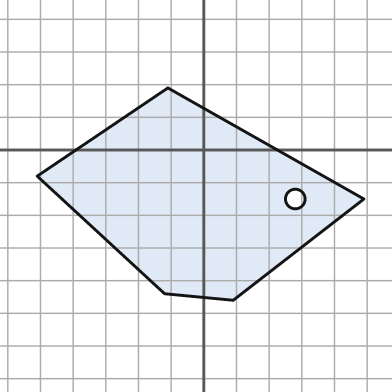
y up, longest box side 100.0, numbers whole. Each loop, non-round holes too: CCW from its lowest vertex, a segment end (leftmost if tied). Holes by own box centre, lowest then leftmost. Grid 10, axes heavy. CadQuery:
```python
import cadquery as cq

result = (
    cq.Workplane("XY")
    .moveTo(9.0, -46.0)
    .lineTo(49.0, -15.0)
    .lineTo(-11.0, 19.0)
    .lineTo(-51.0, -8.0)
    .lineTo(-12.0, -44.0)
    .close()
    .moveTo(28.0, -15.0)
    .circle(3.0)
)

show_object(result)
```